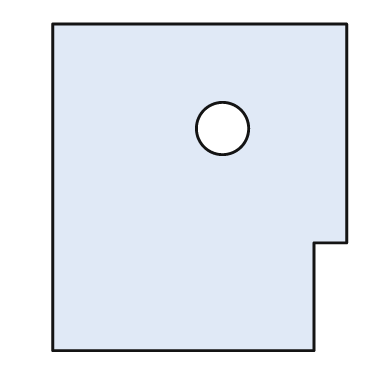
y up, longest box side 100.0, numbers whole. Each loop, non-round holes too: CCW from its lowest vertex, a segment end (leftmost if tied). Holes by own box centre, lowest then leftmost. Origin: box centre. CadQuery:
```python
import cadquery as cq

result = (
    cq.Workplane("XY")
    .moveTo(-45.0, -50.0)
    .lineTo(35.0, -50.0)
    .lineTo(35.0, -17.0)
    .lineTo(45.0, -17.0)
    .lineTo(45.0, 50.0)
    .lineTo(-45.0, 50.0)
    .close()
    .moveTo(7.0, 18.0)
    .circle(8.0)
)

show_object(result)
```